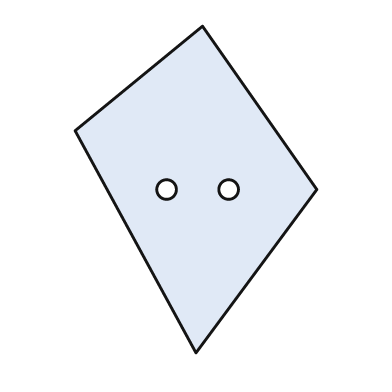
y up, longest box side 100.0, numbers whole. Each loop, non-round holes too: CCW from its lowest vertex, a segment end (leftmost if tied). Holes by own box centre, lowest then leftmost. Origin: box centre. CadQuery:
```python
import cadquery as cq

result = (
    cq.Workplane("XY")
    .moveTo(0.0, -50.0)
    .lineTo(37.0, 0.0)
    .lineTo(2.0, 50.0)
    .lineTo(-37.0, 18.0)
    .close()
    .moveTo(-9.0, 0.0)
    .circle(3.0)
    .moveTo(10.0, 0.0)
    .circle(3.0)
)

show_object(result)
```